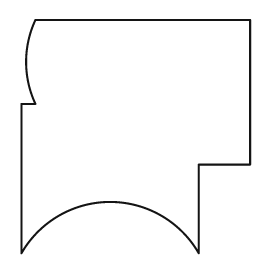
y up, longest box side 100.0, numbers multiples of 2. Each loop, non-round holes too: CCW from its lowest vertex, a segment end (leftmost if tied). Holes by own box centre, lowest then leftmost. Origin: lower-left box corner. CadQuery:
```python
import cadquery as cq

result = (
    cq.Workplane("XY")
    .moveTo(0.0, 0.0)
    .threePointArc((38.0, 22.0), (76.0, 0.0))
    .lineTo(76.0, 38.0)
    .lineTo(98.0, 38.0)
    .lineTo(98.0, 100.0)
    .lineTo(6.0, 100.0)
    .threePointArc((2.0, 82.0), (6.0, 64.0))
    .lineTo(0.0, 64.0)
    .close()
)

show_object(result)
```